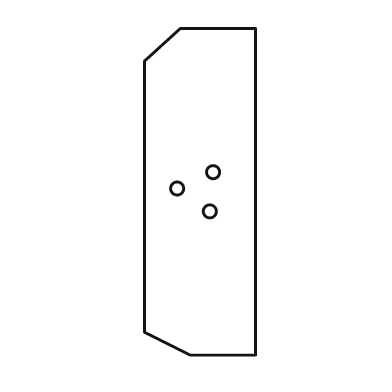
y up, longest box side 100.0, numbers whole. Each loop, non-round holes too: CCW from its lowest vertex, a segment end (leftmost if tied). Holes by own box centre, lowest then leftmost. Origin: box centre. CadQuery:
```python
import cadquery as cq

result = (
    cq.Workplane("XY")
    .moveTo(-3.0, -50.0)
    .lineTo(17.0, -50.0)
    .lineTo(17.0, 50.0)
    .lineTo(-6.0, 50.0)
    .lineTo(-17.0, 40.0)
    .lineTo(-17.0, -43.0)
    .close()
    .moveTo(3.0, -6.0)
    .circle(2.0)
    .moveTo(-7.0, 1.0)
    .circle(2.0)
    .moveTo(4.0, 6.0)
    .circle(2.0)
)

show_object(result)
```